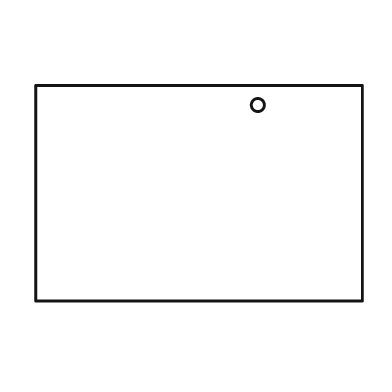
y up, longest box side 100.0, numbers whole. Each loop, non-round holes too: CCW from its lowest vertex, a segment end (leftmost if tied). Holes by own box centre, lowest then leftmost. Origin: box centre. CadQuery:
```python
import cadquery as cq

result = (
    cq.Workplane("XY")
    .moveTo(-50.0, -33.0)
    .lineTo(50.0, -33.0)
    .lineTo(50.0, 33.0)
    .lineTo(-50.0, 33.0)
    .close()
    .moveTo(18.0, 27.0)
    .circle(2.0)
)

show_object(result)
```